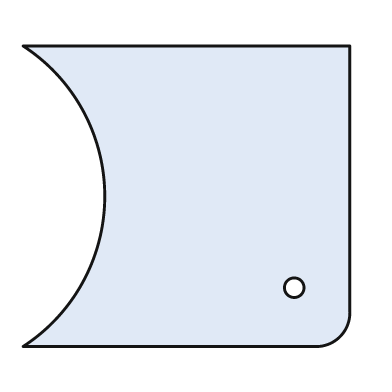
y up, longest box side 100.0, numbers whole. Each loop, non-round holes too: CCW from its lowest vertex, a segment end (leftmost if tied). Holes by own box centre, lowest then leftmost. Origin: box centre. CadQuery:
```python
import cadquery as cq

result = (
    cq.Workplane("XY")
    .moveTo(-50.0, -46.0)
    .lineTo(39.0, -46.0)
    .threePointArc((47.0, -43.0), (50.0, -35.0))
    .lineTo(50.0, 46.0)
    .lineTo(-50.0, 46.0)
    .threePointArc((-25.0, 0.0), (-50.0, -46.0))
    .close()
    .moveTo(33.0, -28.0)
    .circle(3.0)
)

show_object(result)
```